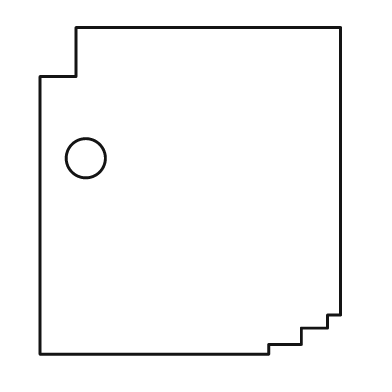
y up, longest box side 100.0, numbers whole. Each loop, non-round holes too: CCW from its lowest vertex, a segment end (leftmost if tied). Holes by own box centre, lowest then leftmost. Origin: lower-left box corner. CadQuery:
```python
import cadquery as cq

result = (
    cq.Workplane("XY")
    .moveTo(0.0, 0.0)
    .lineTo(70.0, 0.0)
    .lineTo(70.0, 3.0)
    .lineTo(80.0, 3.0)
    .lineTo(80.0, 8.0)
    .lineTo(88.0, 8.0)
    .lineTo(88.0, 12.0)
    .lineTo(92.0, 12.0)
    .lineTo(92.0, 100.0)
    .lineTo(11.0, 100.0)
    .lineTo(11.0, 85.0)
    .lineTo(0.0, 85.0)
    .close()
    .moveTo(14.0, 60.0)
    .circle(6.0)
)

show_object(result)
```